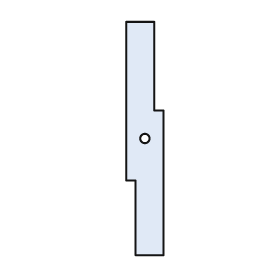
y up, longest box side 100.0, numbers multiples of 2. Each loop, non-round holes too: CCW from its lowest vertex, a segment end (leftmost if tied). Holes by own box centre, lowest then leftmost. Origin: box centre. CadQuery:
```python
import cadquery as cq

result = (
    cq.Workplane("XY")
    .moveTo(-4.0, -50.0)
    .lineTo(8.0, -50.0)
    .lineTo(8.0, 12.0)
    .lineTo(4.0, 12.0)
    .lineTo(4.0, 50.0)
    .lineTo(-8.0, 50.0)
    .lineTo(-8.0, -18.0)
    .lineTo(-4.0, -18.0)
    .close()
    .moveTo(0.0, 0.0)
    .circle(2.0)
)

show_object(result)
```